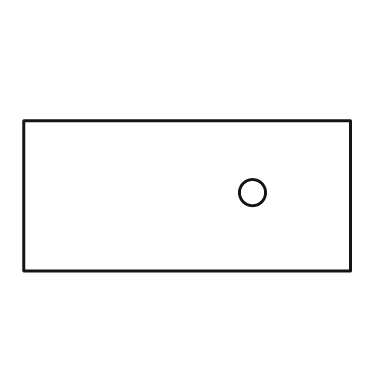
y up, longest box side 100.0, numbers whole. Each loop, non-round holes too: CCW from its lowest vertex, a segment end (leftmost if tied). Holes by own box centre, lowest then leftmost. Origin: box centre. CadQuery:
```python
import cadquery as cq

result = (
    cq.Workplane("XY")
    .moveTo(-50.0, -23.0)
    .lineTo(50.0, -23.0)
    .lineTo(50.0, 23.0)
    .lineTo(-50.0, 23.0)
    .close()
    .moveTo(20.0, 1.0)
    .circle(4.0)
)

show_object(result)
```